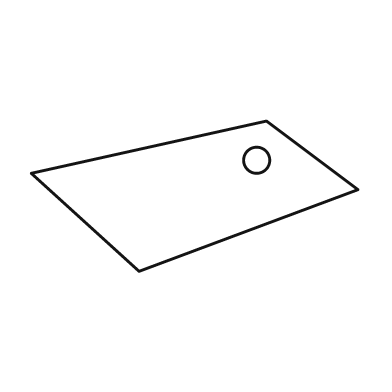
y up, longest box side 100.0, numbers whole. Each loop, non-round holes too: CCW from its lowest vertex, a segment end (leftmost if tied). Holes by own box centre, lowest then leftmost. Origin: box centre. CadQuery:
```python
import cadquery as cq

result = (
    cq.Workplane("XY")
    .moveTo(-17.0, -23.0)
    .lineTo(50.0, 2.0)
    .lineTo(22.0, 23.0)
    .lineTo(-50.0, 7.0)
    .close()
    .moveTo(19.0, 11.0)
    .circle(4.0)
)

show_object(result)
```